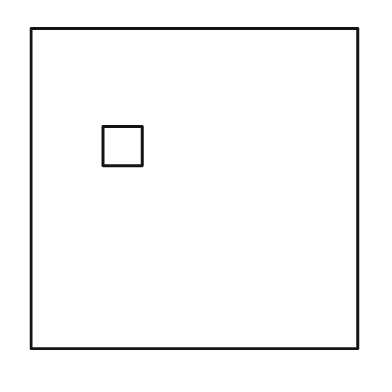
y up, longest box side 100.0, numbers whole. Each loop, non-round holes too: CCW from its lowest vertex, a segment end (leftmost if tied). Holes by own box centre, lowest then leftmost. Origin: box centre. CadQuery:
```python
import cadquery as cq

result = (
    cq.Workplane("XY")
    .moveTo(-50.0, -49.0)
    .lineTo(50.0, -49.0)
    .lineTo(50.0, 49.0)
    .lineTo(-50.0, 49.0)
    .close()
    .moveTo(-28.0, 7.0)
    .lineTo(-16.0, 7.0)
    .lineTo(-16.0, 19.0)
    .lineTo(-28.0, 19.0)
    .close()
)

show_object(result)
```